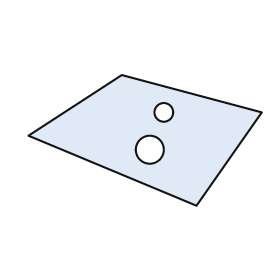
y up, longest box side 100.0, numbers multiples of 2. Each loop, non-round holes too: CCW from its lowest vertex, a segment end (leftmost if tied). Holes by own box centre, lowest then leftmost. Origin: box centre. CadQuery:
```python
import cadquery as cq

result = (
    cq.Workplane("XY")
    .moveTo(22.0, -28.0)
    .lineTo(50.0, 12.0)
    .lineTo(-10.0, 28.0)
    .lineTo(-50.0, 2.0)
    .close()
    .moveTo(2.0, -4.0)
    .circle(6.0)
    .moveTo(8.0, 12.0)
    .circle(4.0)
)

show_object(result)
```